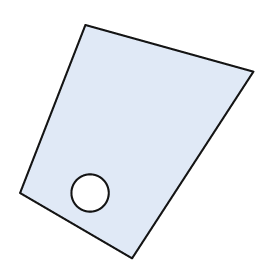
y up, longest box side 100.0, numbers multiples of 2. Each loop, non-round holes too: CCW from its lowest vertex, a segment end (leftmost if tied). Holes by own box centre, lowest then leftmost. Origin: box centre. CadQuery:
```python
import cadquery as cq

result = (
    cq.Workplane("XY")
    .moveTo(-2.0, -50.0)
    .lineTo(50.0, 30.0)
    .lineTo(-22.0, 50.0)
    .lineTo(-50.0, -22.0)
    .close()
    .moveTo(-20.0, -22.0)
    .circle(8.0)
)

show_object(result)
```